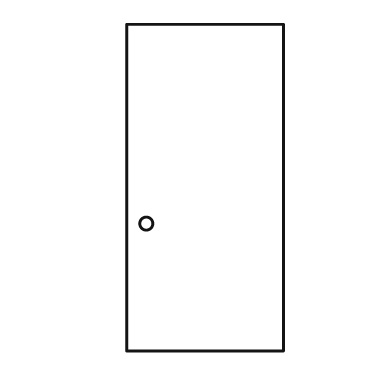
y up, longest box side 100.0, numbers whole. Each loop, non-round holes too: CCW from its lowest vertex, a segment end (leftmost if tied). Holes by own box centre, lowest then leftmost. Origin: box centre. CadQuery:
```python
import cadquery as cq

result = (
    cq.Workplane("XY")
    .moveTo(-24.0, -50.0)
    .lineTo(24.0, -50.0)
    .lineTo(24.0, 50.0)
    .lineTo(-24.0, 50.0)
    .close()
    .moveTo(-18.0, -11.0)
    .circle(2.0)
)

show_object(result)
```